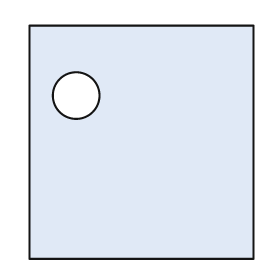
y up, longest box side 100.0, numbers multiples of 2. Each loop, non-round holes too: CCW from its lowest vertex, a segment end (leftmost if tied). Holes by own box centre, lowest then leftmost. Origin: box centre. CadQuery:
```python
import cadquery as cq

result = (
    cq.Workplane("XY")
    .moveTo(-48.0, -50.0)
    .lineTo(48.0, -50.0)
    .lineTo(48.0, 50.0)
    .lineTo(-48.0, 50.0)
    .close()
    .moveTo(-28.0, 20.0)
    .circle(10.0)
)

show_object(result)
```